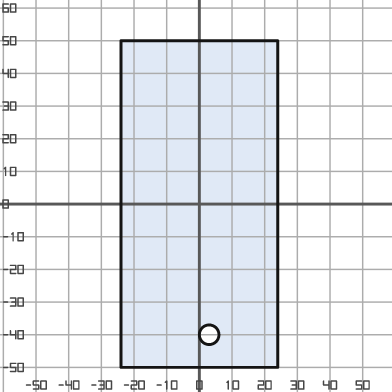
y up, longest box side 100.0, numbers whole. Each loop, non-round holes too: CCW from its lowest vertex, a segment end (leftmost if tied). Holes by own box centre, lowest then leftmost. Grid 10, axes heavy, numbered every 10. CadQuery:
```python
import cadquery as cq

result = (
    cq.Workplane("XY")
    .moveTo(-24.0, -50.0)
    .lineTo(24.0, -50.0)
    .lineTo(24.0, 50.0)
    .lineTo(-24.0, 50.0)
    .close()
    .moveTo(3.0, -40.0)
    .circle(3.0)
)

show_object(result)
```